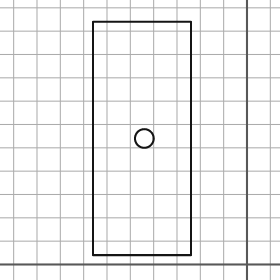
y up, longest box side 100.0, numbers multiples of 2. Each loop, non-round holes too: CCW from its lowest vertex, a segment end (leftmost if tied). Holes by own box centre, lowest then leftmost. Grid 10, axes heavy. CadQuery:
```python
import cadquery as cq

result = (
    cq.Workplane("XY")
    .moveTo(-66.0, 4.0)
    .lineTo(-24.0, 4.0)
    .lineTo(-24.0, 104.0)
    .lineTo(-66.0, 104.0)
    .close()
    .moveTo(-44.0, 54.0)
    .circle(4.0)
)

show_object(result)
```